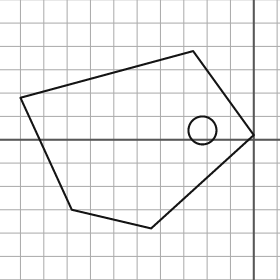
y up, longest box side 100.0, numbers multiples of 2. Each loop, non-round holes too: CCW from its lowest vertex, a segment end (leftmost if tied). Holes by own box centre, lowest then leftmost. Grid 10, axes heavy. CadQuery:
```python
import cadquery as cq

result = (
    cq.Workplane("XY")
    .moveTo(-44.0, -38.0)
    .lineTo(0.0, 2.0)
    .lineTo(-26.0, 38.0)
    .lineTo(-100.0, 18.0)
    .lineTo(-78.0, -30.0)
    .close()
    .moveTo(-22.0, 4.0)
    .circle(6.0)
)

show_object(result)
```